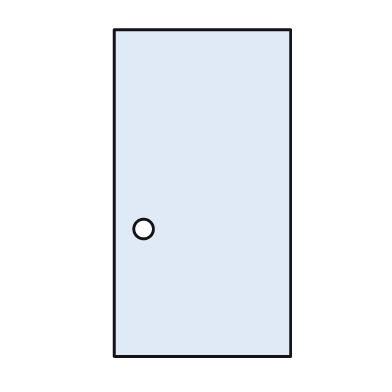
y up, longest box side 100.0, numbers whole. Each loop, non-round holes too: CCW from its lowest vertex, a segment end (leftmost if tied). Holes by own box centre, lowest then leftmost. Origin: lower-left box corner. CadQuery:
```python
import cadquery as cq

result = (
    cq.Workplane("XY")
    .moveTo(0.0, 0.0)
    .lineTo(54.0, 0.0)
    .lineTo(54.0, 100.0)
    .lineTo(0.0, 100.0)
    .close()
    .moveTo(9.0, 39.0)
    .circle(3.0)
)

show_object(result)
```